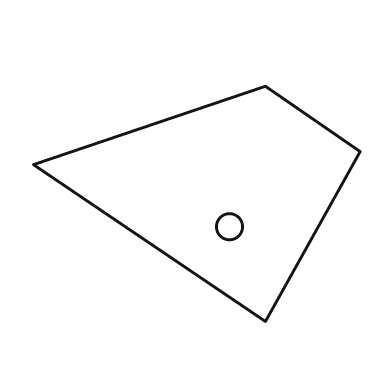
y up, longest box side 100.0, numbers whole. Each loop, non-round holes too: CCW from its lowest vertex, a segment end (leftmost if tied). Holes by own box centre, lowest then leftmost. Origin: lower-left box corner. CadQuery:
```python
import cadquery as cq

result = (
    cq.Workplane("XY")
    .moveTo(71.0, 0.0)
    .lineTo(100.0, 52.0)
    .lineTo(71.0, 72.0)
    .lineTo(0.0, 48.0)
    .close()
    .moveTo(60.0, 29.0)
    .circle(4.0)
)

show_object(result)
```